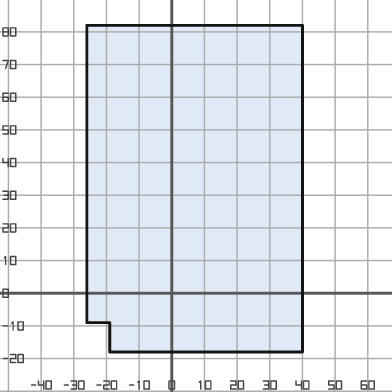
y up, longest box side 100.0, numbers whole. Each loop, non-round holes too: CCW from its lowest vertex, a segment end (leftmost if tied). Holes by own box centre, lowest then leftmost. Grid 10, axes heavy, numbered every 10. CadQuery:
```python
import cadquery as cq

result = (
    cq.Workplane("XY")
    .moveTo(-19.0, -18.0)
    .lineTo(40.0, -18.0)
    .lineTo(40.0, 82.0)
    .lineTo(-26.0, 82.0)
    .lineTo(-26.0, -9.0)
    .lineTo(-19.0, -9.0)
    .close()
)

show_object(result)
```